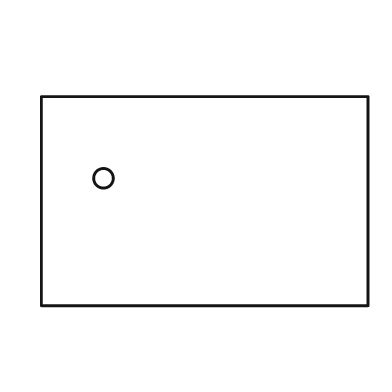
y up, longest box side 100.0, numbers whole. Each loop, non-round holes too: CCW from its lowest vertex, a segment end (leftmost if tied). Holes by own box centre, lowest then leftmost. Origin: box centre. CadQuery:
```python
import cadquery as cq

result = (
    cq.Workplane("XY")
    .moveTo(-50.0, -32.0)
    .lineTo(50.0, -32.0)
    .lineTo(50.0, 32.0)
    .lineTo(-50.0, 32.0)
    .close()
    .moveTo(-31.0, 7.0)
    .circle(3.0)
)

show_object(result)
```